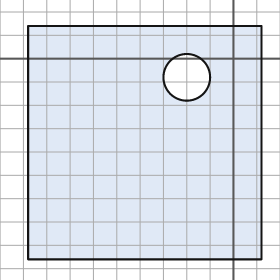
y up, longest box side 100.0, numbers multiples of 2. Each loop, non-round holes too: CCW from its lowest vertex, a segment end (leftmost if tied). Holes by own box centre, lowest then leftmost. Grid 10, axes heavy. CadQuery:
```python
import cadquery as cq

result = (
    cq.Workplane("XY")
    .moveTo(-88.0, -86.0)
    .lineTo(12.0, -86.0)
    .lineTo(12.0, 14.0)
    .lineTo(-88.0, 14.0)
    .close()
    .moveTo(-20.0, -8.0)
    .circle(10.0)
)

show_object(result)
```